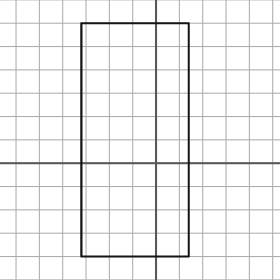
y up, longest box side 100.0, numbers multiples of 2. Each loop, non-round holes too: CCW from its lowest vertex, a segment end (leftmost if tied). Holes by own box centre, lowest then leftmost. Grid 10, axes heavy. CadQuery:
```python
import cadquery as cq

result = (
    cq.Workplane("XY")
    .moveTo(-32.0, -40.0)
    .lineTo(14.0, -40.0)
    .lineTo(14.0, 60.0)
    .lineTo(-32.0, 60.0)
    .close()
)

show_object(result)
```